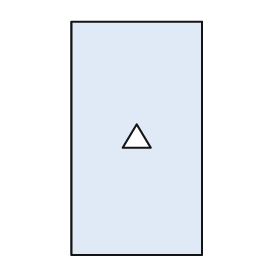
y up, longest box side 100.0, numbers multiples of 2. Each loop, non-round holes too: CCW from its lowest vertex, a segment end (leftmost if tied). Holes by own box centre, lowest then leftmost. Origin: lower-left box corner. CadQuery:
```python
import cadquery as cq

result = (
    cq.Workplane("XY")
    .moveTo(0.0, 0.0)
    .lineTo(56.0, 0.0)
    .lineTo(56.0, 100.0)
    .lineTo(0.0, 100.0)
    .close()
    .moveTo(22.0, 46.0)
    .lineTo(34.0, 46.0)
    .lineTo(28.0, 56.0)
    .close()
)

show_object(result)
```